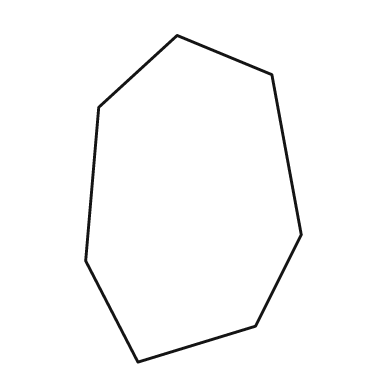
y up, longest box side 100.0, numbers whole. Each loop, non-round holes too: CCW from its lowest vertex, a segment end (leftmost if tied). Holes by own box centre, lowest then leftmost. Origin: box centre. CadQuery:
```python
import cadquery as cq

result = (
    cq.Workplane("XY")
    .moveTo(-17.0, -50.0)
    .lineTo(19.0, -39.0)
    .lineTo(33.0, -11.0)
    .lineTo(24.0, 38.0)
    .lineTo(-5.0, 50.0)
    .lineTo(-29.0, 28.0)
    .lineTo(-33.0, -19.0)
    .close()
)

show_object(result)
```